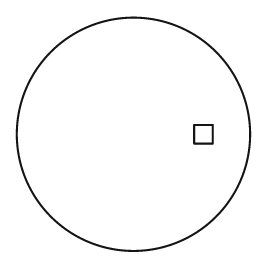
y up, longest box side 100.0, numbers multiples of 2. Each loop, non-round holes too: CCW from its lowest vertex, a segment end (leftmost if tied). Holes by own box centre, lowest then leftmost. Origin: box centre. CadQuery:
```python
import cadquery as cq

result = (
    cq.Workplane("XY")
    .moveTo(0.0, 0.0)
    .circle(50.0)
    .moveTo(26.0, -4.0)
    .lineTo(34.0, -4.0)
    .lineTo(34.0, 4.0)
    .lineTo(26.0, 4.0)
    .close()
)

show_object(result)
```